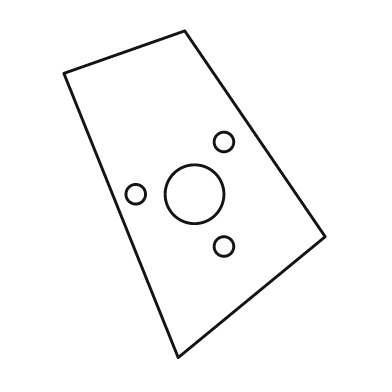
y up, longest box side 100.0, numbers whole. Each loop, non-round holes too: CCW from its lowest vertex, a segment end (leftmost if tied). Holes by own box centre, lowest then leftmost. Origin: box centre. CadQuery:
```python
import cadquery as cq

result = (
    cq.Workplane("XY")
    .moveTo(-5.0, -50.0)
    .lineTo(40.0, -13.0)
    .lineTo(-3.0, 50.0)
    .lineTo(-40.0, 37.0)
    .close()
    .moveTo(9.0, -16.0)
    .circle(3.0)
    .moveTo(-18.0, 0.0)
    .circle(3.0)
    .moveTo(0.0, 0.0)
    .circle(9.0)
    .moveTo(9.0, 16.0)
    .circle(3.0)
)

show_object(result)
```